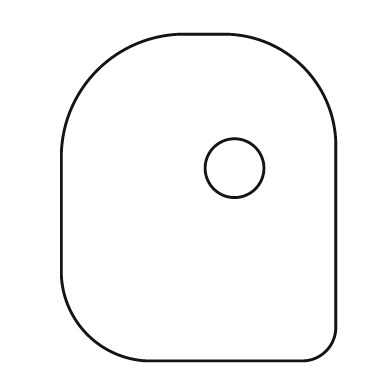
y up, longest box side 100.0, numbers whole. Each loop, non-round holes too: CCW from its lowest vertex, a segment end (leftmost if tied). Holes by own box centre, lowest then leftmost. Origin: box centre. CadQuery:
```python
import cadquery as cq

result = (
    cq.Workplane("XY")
    .moveTo(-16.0, -50.0)
    .lineTo(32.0, -50.0)
    .threePointArc((39.0, -47.0), (42.0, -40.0))
    .lineTo(42.0, 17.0)
    .threePointArc((32.0, 40.0), (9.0, 50.0))
    .lineTo(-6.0, 50.0)
    .threePointArc((-31.0, 39.0), (-42.0, 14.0))
    .lineTo(-42.0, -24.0)
    .threePointArc((-34.0, -42.0), (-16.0, -50.0))
    .close()
    .moveTo(11.0, 9.0)
    .circle(9.0)
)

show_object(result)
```